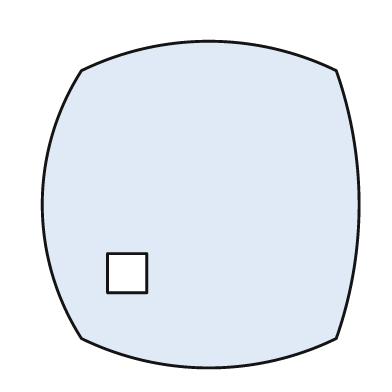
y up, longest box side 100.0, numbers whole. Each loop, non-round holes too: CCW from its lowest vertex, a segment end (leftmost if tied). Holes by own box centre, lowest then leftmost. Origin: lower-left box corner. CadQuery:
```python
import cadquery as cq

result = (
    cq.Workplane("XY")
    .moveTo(12.0, 9.0)
    .threePointArc((51.0, 0.0), (90.0, 9.0))
    .threePointArc((97.0, 50.0), (90.0, 91.0))
    .threePointArc((51.0, 100.0), (12.0, 91.0))
    .threePointArc((0.0, 50.0), (12.0, 9.0))
    .close()
    .moveTo(20.0, 23.0)
    .lineTo(32.0, 23.0)
    .lineTo(32.0, 35.0)
    .lineTo(20.0, 35.0)
    .close()
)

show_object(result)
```